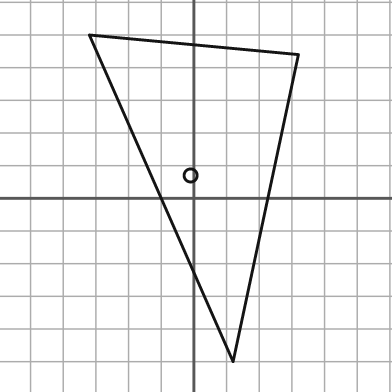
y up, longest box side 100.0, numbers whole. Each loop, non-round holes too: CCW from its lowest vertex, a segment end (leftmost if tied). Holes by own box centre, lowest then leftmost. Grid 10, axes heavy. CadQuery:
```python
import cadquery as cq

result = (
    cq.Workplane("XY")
    .moveTo(12.0, -50.0)
    .lineTo(32.0, 44.0)
    .lineTo(-32.0, 50.0)
    .close()
    .moveTo(-1.0, 7.0)
    .circle(2.0)
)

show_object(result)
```